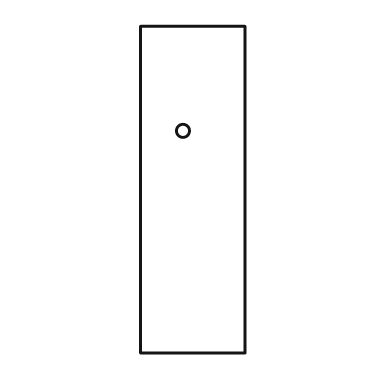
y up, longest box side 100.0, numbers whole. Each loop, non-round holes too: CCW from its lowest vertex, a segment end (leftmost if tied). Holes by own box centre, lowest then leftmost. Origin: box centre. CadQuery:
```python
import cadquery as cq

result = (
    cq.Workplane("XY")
    .moveTo(-16.0, -50.0)
    .lineTo(16.0, -50.0)
    .lineTo(16.0, 50.0)
    .lineTo(-16.0, 50.0)
    .close()
    .moveTo(-3.0, 18.0)
    .circle(2.0)
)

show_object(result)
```